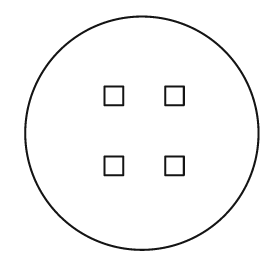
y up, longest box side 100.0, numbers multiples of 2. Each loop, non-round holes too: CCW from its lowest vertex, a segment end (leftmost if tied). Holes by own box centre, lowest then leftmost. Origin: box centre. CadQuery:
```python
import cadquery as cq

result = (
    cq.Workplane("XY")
    .moveTo(0.0, 0.0)
    .circle(50.0)
    .moveTo(-16.0, -18.0)
    .lineTo(-8.0, -18.0)
    .lineTo(-8.0, -10.0)
    .lineTo(-16.0, -10.0)
    .close()
    .moveTo(10.0, -18.0)
    .lineTo(18.0, -18.0)
    .lineTo(18.0, -10.0)
    .lineTo(10.0, -10.0)
    .close()
    .moveTo(-16.0, 12.0)
    .lineTo(-8.0, 12.0)
    .lineTo(-8.0, 20.0)
    .lineTo(-16.0, 20.0)
    .close()
    .moveTo(10.0, 12.0)
    .lineTo(18.0, 12.0)
    .lineTo(18.0, 20.0)
    .lineTo(10.0, 20.0)
    .close()
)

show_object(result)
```